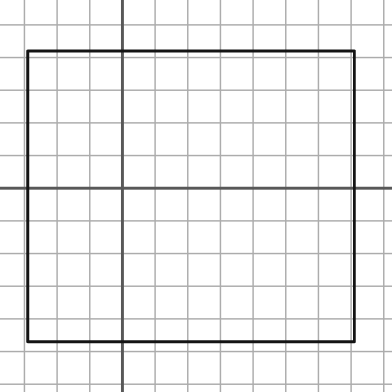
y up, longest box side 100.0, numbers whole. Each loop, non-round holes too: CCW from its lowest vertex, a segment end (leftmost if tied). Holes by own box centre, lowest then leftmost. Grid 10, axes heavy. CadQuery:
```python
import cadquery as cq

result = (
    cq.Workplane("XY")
    .moveTo(-29.0, -47.0)
    .lineTo(71.0, -47.0)
    .lineTo(71.0, 42.0)
    .lineTo(-29.0, 42.0)
    .close()
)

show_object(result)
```